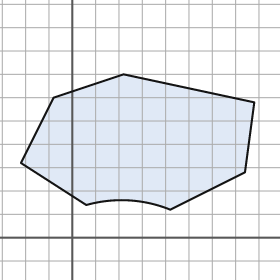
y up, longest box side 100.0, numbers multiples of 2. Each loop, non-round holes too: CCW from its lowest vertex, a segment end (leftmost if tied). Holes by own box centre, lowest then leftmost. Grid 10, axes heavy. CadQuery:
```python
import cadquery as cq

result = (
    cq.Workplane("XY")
    .moveTo(42.0, 12.0)
    .lineTo(74.0, 28.0)
    .lineTo(78.0, 58.0)
    .lineTo(22.0, 70.0)
    .lineTo(-8.0, 60.0)
    .lineTo(-22.0, 32.0)
    .lineTo(6.0, 14.0)
    .threePointArc((24.0, 16.0), (42.0, 12.0))
    .close()
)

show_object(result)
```